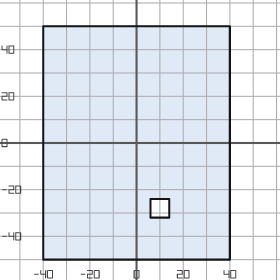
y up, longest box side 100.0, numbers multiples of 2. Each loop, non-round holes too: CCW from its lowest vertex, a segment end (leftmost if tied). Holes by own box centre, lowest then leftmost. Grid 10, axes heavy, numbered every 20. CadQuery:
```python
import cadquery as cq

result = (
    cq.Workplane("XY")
    .moveTo(-40.0, -50.0)
    .lineTo(40.0, -50.0)
    .lineTo(40.0, 50.0)
    .lineTo(-40.0, 50.0)
    .close()
    .moveTo(6.0, -32.0)
    .lineTo(14.0, -32.0)
    .lineTo(14.0, -24.0)
    .lineTo(6.0, -24.0)
    .close()
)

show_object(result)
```